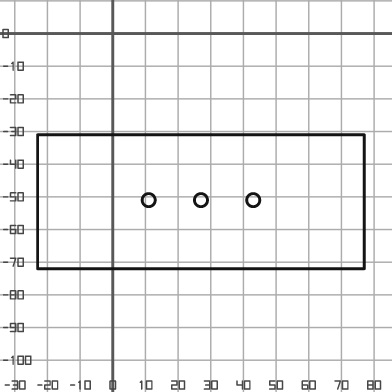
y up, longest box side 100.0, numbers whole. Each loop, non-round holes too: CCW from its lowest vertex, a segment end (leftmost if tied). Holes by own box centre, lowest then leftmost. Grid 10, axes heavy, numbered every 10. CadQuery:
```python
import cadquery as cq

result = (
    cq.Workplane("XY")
    .moveTo(-23.0, -72.0)
    .lineTo(77.0, -72.0)
    .lineTo(77.0, -31.0)
    .lineTo(-23.0, -31.0)
    .close()
    .moveTo(11.0, -51.0)
    .circle(2.0)
    .moveTo(27.0, -51.0)
    .circle(2.0)
    .moveTo(43.0, -51.0)
    .circle(2.0)
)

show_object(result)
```